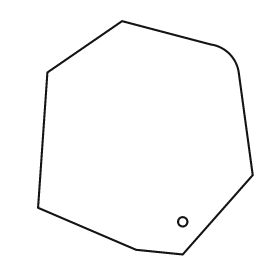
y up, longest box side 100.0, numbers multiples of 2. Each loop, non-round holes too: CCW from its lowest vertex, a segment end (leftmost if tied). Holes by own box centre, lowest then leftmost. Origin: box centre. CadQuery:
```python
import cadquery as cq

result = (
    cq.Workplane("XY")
    .moveTo(16.0, -50.0)
    .lineTo(46.0, -16.0)
    .lineTo(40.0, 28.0)
    .threePointArc((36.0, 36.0), (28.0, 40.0))
    .lineTo(-10.0, 50.0)
    .lineTo(-42.0, 28.0)
    .lineTo(-46.0, -30.0)
    .lineTo(-4.0, -48.0)
    .close()
    .moveTo(16.0, -36.0)
    .circle(2.0)
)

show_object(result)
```